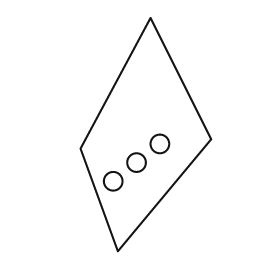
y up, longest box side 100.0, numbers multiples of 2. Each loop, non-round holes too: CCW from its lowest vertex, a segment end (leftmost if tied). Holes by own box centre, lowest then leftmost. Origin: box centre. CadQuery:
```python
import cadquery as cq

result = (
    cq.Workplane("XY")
    .moveTo(-12.0, -50.0)
    .lineTo(28.0, -2.0)
    .lineTo(2.0, 50.0)
    .lineTo(-28.0, -6.0)
    .close()
    .moveTo(-14.0, -20.0)
    .circle(4.0)
    .moveTo(-4.0, -12.0)
    .circle(4.0)
    .moveTo(6.0, -4.0)
    .circle(4.0)
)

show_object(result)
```